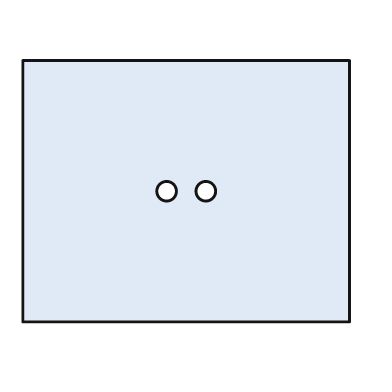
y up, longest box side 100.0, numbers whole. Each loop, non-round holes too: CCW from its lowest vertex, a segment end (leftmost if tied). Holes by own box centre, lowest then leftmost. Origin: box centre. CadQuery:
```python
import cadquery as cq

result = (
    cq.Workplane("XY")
    .moveTo(-50.0, -40.0)
    .lineTo(50.0, -40.0)
    .lineTo(50.0, 40.0)
    .lineTo(-50.0, 40.0)
    .close()
    .moveTo(-6.0, 0.0)
    .circle(3.0)
    .moveTo(6.0, 0.0)
    .circle(3.0)
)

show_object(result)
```